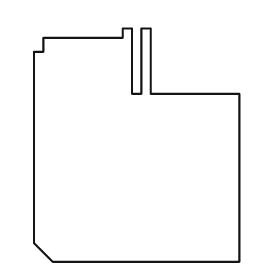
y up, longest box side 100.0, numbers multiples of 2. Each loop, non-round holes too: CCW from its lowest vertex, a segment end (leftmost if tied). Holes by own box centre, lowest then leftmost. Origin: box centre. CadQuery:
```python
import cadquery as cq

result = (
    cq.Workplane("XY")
    .moveTo(-36.0, -50.0)
    .lineTo(44.0, -50.0)
    .lineTo(44.0, 22.0)
    .lineTo(6.0, 22.0)
    .lineTo(6.0, 50.0)
    .lineTo(2.0, 50.0)
    .lineTo(2.0, 22.0)
    .lineTo(-2.0, 22.0)
    .lineTo(-2.0, 50.0)
    .lineTo(-6.0, 50.0)
    .lineTo(-6.0, 46.0)
    .lineTo(-40.0, 46.0)
    .lineTo(-40.0, 40.0)
    .lineTo(-44.0, 40.0)
    .lineTo(-44.0, -42.0)
    .close()
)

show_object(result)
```